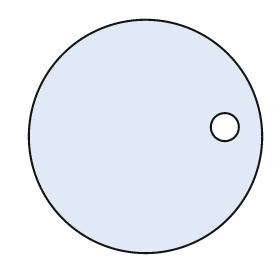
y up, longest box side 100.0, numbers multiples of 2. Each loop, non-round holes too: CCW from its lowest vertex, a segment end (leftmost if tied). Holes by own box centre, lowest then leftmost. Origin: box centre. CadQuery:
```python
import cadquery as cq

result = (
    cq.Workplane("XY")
    .moveTo(0.0, 0.0)
    .circle(50.0)
    .moveTo(34.0, 4.0)
    .circle(6.0)
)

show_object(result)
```